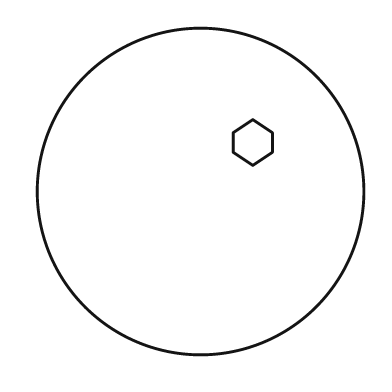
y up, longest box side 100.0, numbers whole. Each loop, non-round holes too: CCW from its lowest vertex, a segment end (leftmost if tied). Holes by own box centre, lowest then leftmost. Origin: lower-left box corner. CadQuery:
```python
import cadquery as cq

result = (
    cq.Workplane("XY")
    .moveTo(50.0, 50.0)
    .circle(50.0)
    .moveTo(66.0, 58.0)
    .lineTo(72.0, 62.0)
    .lineTo(72.0, 68.0)
    .lineTo(66.0, 72.0)
    .lineTo(60.0, 68.0)
    .lineTo(60.0, 62.0)
    .close()
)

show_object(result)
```